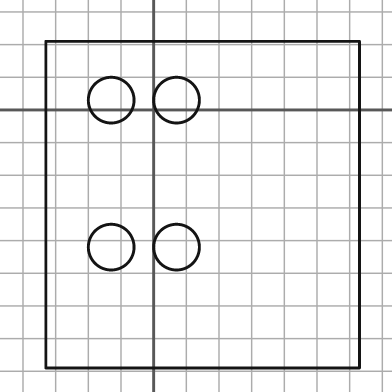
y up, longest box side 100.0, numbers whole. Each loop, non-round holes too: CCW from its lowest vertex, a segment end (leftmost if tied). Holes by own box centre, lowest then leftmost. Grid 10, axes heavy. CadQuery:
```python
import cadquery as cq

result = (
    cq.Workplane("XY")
    .moveTo(-33.0, -79.0)
    .lineTo(63.0, -79.0)
    .lineTo(63.0, 21.0)
    .lineTo(-33.0, 21.0)
    .close()
    .moveTo(-13.0, -42.0)
    .circle(7.0)
    .moveTo(7.0, -42.0)
    .circle(7.0)
    .moveTo(-13.0, 3.0)
    .circle(7.0)
    .moveTo(7.0, 3.0)
    .circle(7.0)
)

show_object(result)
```